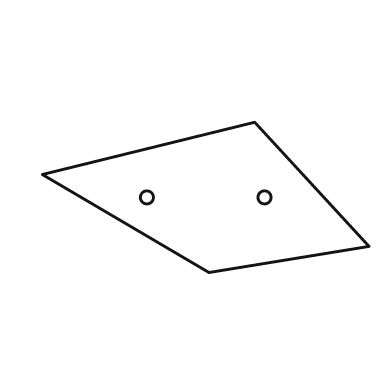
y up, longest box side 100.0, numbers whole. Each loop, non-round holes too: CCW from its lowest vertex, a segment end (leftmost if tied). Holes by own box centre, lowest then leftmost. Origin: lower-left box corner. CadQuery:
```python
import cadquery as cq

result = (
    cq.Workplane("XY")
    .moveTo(51.0, 0.0)
    .lineTo(100.0, 8.0)
    .lineTo(65.0, 46.0)
    .lineTo(0.0, 30.0)
    .close()
    .moveTo(32.0, 23.0)
    .circle(2.0)
    .moveTo(68.0, 23.0)
    .circle(2.0)
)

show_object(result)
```